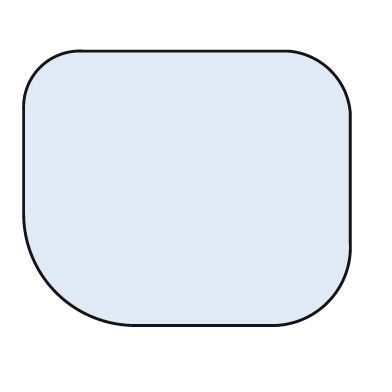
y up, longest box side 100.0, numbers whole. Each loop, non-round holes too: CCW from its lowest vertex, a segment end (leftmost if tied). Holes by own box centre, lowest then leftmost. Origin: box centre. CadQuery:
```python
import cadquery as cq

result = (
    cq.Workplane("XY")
    .moveTo(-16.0, -42.0)
    .lineTo(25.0, -42.0)
    .threePointArc((43.0, -35.0), (50.0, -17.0))
    .lineTo(50.0, 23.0)
    .threePointArc((44.0, 36.0), (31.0, 42.0))
    .lineTo(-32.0, 42.0)
    .threePointArc((-45.0, 37.0), (-50.0, 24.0))
    .lineTo(-50.0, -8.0)
    .threePointArc((-40.0, -32.0), (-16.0, -42.0))
    .close()
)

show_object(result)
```